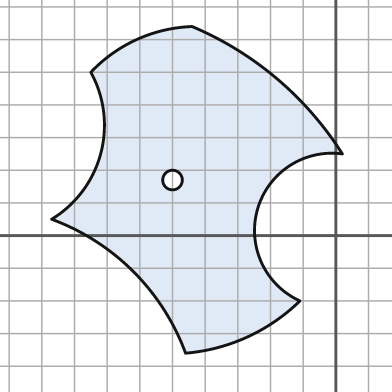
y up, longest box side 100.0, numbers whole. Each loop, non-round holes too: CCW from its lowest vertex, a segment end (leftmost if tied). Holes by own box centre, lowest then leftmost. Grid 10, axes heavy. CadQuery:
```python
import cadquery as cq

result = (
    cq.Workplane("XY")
    .moveTo(-46.0, -36.0)
    .threePointArc((-27.0, -31.0), (-11.0, -20.0))
    .threePointArc((-24.0, 8.0), (2.0, 25.0))
    .threePointArc((-18.0, 48.0), (-44.0, 64.0))
    .threePointArc((-61.0, 60.0), (-75.0, 50.0))
    .threePointArc((-72.0, 25.0), (-87.0, 5.0))
    .threePointArc((-62.0, -11.0), (-46.0, -36.0))
    .close()
    .moveTo(-50.0, 17.0)
    .circle(3.0)
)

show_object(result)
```